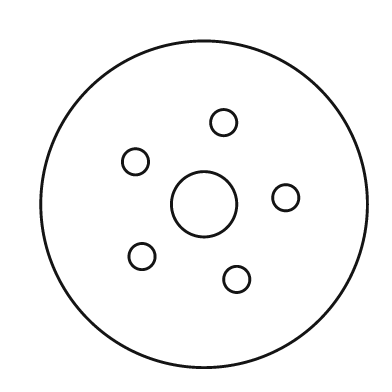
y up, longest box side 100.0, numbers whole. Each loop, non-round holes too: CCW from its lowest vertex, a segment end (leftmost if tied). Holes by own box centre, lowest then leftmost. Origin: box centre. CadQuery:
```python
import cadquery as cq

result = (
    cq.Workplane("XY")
    .moveTo(0.0, 0.0)
    .circle(50.0)
    .moveTo(10.0, -23.0)
    .circle(4.0)
    .moveTo(-19.0, -16.0)
    .circle(4.0)
    .moveTo(0.0, 0.0)
    .circle(10.0)
    .moveTo(25.0, 2.0)
    .circle(4.0)
    .moveTo(-21.0, 13.0)
    .circle(4.0)
    .moveTo(6.0, 25.0)
    .circle(4.0)
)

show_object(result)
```